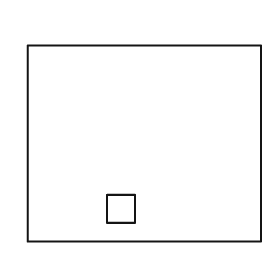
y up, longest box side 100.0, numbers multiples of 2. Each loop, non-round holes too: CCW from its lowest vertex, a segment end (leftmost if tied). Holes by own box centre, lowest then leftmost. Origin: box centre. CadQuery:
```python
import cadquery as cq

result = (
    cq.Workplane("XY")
    .moveTo(-50.0, -42.0)
    .lineTo(50.0, -42.0)
    .lineTo(50.0, 42.0)
    .lineTo(-50.0, 42.0)
    .close()
    .moveTo(-16.0, -34.0)
    .lineTo(-4.0, -34.0)
    .lineTo(-4.0, -22.0)
    .lineTo(-16.0, -22.0)
    .close()
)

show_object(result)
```